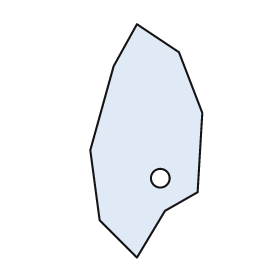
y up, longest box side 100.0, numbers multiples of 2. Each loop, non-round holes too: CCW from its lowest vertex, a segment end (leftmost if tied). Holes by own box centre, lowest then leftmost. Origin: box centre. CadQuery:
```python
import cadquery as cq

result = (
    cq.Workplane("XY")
    .moveTo(-4.0, -50.0)
    .lineTo(8.0, -30.0)
    .lineTo(22.0, -22.0)
    .lineTo(24.0, 12.0)
    .lineTo(14.0, 38.0)
    .lineTo(-4.0, 50.0)
    .lineTo(-14.0, 32.0)
    .lineTo(-24.0, -4.0)
    .lineTo(-20.0, -34.0)
    .close()
    .moveTo(6.0, -16.0)
    .circle(4.0)
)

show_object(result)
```